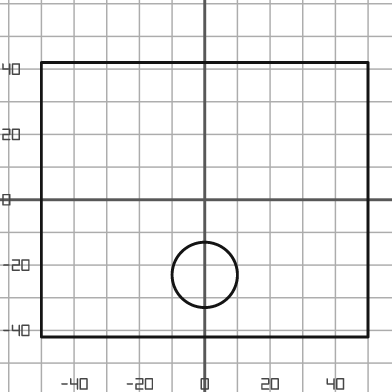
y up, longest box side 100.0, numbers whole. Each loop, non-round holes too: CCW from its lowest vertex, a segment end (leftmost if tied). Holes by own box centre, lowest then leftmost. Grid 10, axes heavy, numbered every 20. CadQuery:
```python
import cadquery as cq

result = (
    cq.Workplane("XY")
    .moveTo(-50.0, -42.0)
    .lineTo(50.0, -42.0)
    .lineTo(50.0, 42.0)
    .lineTo(-50.0, 42.0)
    .close()
    .moveTo(0.0, -23.0)
    .circle(10.0)
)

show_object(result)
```